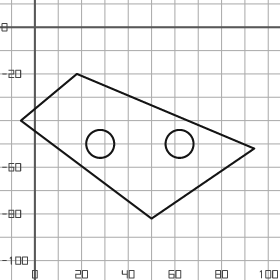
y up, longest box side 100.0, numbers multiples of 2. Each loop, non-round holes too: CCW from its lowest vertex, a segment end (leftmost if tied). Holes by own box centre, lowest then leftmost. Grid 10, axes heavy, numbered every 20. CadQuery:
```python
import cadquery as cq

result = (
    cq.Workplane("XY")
    .moveTo(50.0, -82.0)
    .lineTo(94.0, -52.0)
    .lineTo(18.0, -20.0)
    .lineTo(-6.0, -40.0)
    .close()
    .moveTo(28.0, -50.0)
    .circle(6.0)
    .moveTo(62.0, -50.0)
    .circle(6.0)
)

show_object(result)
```